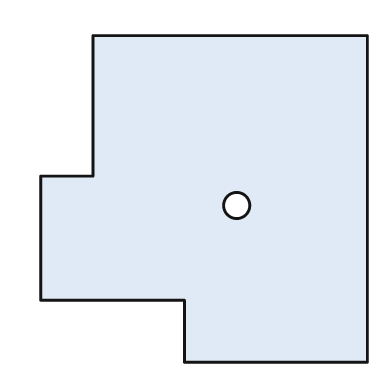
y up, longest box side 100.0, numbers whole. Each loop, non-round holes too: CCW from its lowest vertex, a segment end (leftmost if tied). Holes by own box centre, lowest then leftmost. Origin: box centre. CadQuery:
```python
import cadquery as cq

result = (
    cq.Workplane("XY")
    .moveTo(-6.0, -50.0)
    .lineTo(50.0, -50.0)
    .lineTo(50.0, 50.0)
    .lineTo(-34.0, 50.0)
    .lineTo(-34.0, 7.0)
    .lineTo(-50.0, 7.0)
    .lineTo(-50.0, -31.0)
    .lineTo(-6.0, -31.0)
    .close()
    .moveTo(10.0, -2.0)
    .circle(4.0)
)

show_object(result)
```